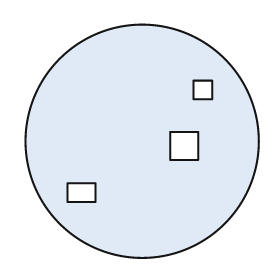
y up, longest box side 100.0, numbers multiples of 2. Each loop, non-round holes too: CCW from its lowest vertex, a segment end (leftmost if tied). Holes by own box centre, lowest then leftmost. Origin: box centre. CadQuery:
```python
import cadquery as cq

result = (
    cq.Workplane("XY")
    .moveTo(0.0, 0.0)
    .circle(50.0)
    .moveTo(-32.0, -26.0)
    .lineTo(-20.0, -26.0)
    .lineTo(-20.0, -18.0)
    .lineTo(-32.0, -18.0)
    .close()
    .moveTo(12.0, -8.0)
    .lineTo(24.0, -8.0)
    .lineTo(24.0, 4.0)
    .lineTo(12.0, 4.0)
    .close()
    .moveTo(22.0, 18.0)
    .lineTo(30.0, 18.0)
    .lineTo(30.0, 26.0)
    .lineTo(22.0, 26.0)
    .close()
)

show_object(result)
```